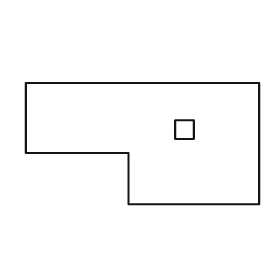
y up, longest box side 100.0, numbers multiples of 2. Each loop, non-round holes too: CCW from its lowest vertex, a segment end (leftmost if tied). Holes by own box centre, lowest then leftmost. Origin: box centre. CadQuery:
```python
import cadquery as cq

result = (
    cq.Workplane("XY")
    .moveTo(-6.0, -26.0)
    .lineTo(50.0, -26.0)
    .lineTo(50.0, 26.0)
    .lineTo(-50.0, 26.0)
    .lineTo(-50.0, -4.0)
    .lineTo(-6.0, -4.0)
    .close()
    .moveTo(14.0, 2.0)
    .lineTo(22.0, 2.0)
    .lineTo(22.0, 10.0)
    .lineTo(14.0, 10.0)
    .close()
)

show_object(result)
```